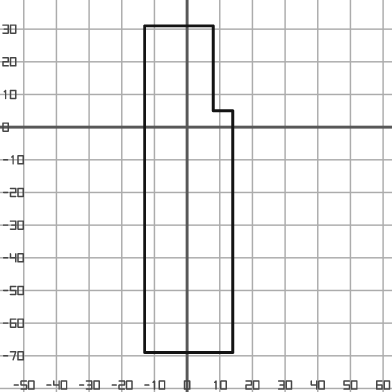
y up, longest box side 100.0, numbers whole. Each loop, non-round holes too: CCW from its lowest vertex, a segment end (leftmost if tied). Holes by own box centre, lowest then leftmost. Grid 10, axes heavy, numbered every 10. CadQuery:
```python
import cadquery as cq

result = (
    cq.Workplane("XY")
    .moveTo(-13.0, -69.0)
    .lineTo(14.0, -69.0)
    .lineTo(14.0, 5.0)
    .lineTo(8.0, 5.0)
    .lineTo(8.0, 31.0)
    .lineTo(-13.0, 31.0)
    .close()
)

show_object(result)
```